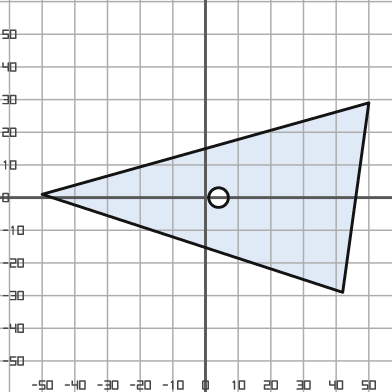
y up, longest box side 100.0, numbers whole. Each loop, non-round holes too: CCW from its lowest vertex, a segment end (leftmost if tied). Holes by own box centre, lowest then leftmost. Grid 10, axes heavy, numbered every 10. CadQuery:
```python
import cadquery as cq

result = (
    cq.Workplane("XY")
    .moveTo(42.0, -29.0)
    .lineTo(50.0, 29.0)
    .lineTo(-50.0, 1.0)
    .close()
    .moveTo(4.0, 0.0)
    .circle(3.0)
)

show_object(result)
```